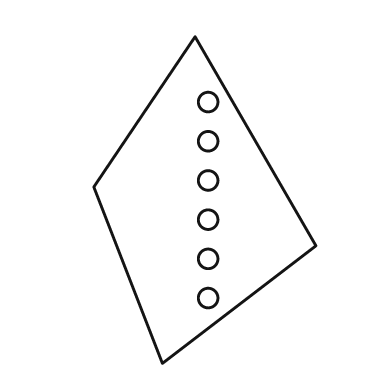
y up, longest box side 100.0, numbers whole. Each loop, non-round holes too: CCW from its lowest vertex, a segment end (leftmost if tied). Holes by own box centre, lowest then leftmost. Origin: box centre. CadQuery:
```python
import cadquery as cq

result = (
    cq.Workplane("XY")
    .moveTo(-13.0, -50.0)
    .lineTo(34.0, -14.0)
    .lineTo(-3.0, 50.0)
    .lineTo(-34.0, 4.0)
    .close()
    .moveTo(1.0, -30.0)
    .circle(3.0)
    .moveTo(1.0, -18.0)
    .circle(3.0)
    .moveTo(1.0, -6.0)
    .circle(3.0)
    .moveTo(1.0, 6.0)
    .circle(3.0)
    .moveTo(1.0, 18.0)
    .circle(3.0)
    .moveTo(1.0, 30.0)
    .circle(3.0)
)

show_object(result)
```